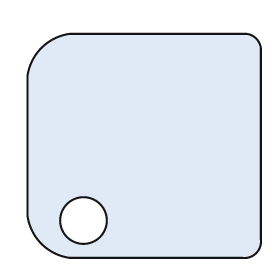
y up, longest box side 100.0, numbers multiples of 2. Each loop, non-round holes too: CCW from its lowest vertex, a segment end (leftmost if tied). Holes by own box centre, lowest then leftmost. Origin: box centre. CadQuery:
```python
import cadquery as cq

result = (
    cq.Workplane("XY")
    .moveTo(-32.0, -48.0)
    .lineTo(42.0, -48.0)
    .threePointArc((48.0, -46.0), (50.0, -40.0))
    .lineTo(50.0, 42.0)
    .threePointArc((48.0, 46.0), (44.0, 48.0))
    .lineTo(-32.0, 48.0)
    .threePointArc((-44.0, 42.0), (-50.0, 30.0))
    .lineTo(-50.0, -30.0)
    .threePointArc((-44.0, -42.0), (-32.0, -48.0))
    .close()
    .moveTo(-26.0, -32.0)
    .circle(10.0)
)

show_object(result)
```